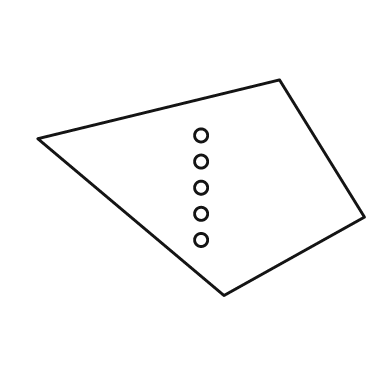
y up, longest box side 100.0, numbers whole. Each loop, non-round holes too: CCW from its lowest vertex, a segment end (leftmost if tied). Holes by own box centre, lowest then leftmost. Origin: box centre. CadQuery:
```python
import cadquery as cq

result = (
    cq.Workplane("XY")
    .moveTo(7.0, -33.0)
    .lineTo(50.0, -9.0)
    .lineTo(24.0, 33.0)
    .lineTo(-50.0, 15.0)
    .close()
    .moveTo(0.0, -16.0)
    .circle(2.0)
    .moveTo(0.0, -8.0)
    .circle(2.0)
    .moveTo(0.0, 0.0)
    .circle(2.0)
    .moveTo(0.0, 8.0)
    .circle(2.0)
    .moveTo(0.0, 16.0)
    .circle(2.0)
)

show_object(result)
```